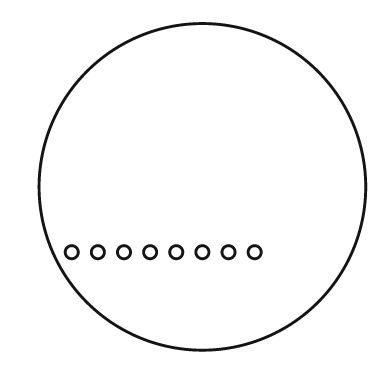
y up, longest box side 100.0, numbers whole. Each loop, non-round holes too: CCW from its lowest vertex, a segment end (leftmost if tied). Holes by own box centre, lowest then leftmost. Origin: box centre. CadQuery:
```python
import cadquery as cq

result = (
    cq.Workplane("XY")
    .moveTo(0.0, 0.0)
    .circle(50.0)
    .moveTo(-40.0, -20.0)
    .circle(2.0)
    .moveTo(-32.0, -20.0)
    .circle(2.0)
    .moveTo(-24.0, -20.0)
    .circle(2.0)
    .moveTo(-16.0, -20.0)
    .circle(2.0)
    .moveTo(-8.0, -20.0)
    .circle(2.0)
    .moveTo(0.0, -20.0)
    .circle(2.0)
    .moveTo(8.0, -20.0)
    .circle(2.0)
    .moveTo(16.0, -20.0)
    .circle(2.0)
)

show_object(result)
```